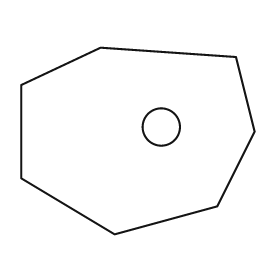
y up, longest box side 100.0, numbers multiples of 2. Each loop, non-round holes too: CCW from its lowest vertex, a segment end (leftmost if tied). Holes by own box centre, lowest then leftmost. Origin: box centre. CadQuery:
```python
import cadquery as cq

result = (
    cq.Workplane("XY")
    .moveTo(-10.0, -40.0)
    .lineTo(34.0, -28.0)
    .lineTo(50.0, 4.0)
    .lineTo(42.0, 36.0)
    .lineTo(-16.0, 40.0)
    .lineTo(-50.0, 24.0)
    .lineTo(-50.0, -16.0)
    .close()
    .moveTo(10.0, 6.0)
    .circle(8.0)
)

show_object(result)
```